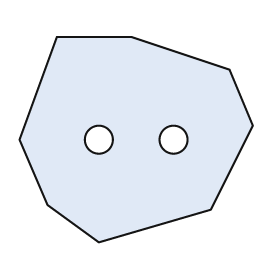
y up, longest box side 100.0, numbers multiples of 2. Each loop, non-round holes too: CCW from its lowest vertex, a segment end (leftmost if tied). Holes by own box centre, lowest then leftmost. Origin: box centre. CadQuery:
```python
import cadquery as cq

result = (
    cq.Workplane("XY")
    .moveTo(-16.0, -44.0)
    .lineTo(32.0, -30.0)
    .lineTo(50.0, 6.0)
    .lineTo(40.0, 30.0)
    .lineTo(-2.0, 44.0)
    .lineTo(-34.0, 44.0)
    .lineTo(-50.0, 0.0)
    .lineTo(-38.0, -28.0)
    .close()
    .moveTo(-16.0, 0.0)
    .circle(6.0)
    .moveTo(16.0, 0.0)
    .circle(6.0)
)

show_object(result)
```